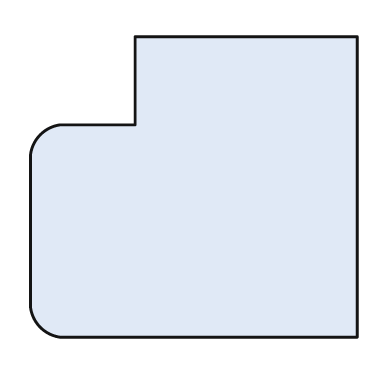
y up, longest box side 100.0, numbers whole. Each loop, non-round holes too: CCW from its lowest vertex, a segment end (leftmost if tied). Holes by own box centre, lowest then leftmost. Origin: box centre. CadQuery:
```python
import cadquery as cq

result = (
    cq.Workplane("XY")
    .moveTo(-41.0, -46.0)
    .lineTo(50.0, -46.0)
    .lineTo(50.0, 46.0)
    .lineTo(-18.0, 46.0)
    .lineTo(-18.0, 19.0)
    .lineTo(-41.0, 19.0)
    .threePointArc((-47.0, 16.0), (-50.0, 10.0))
    .lineTo(-50.0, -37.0)
    .threePointArc((-47.0, -43.0), (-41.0, -46.0))
    .close()
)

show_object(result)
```